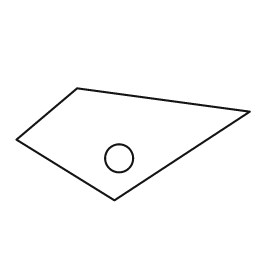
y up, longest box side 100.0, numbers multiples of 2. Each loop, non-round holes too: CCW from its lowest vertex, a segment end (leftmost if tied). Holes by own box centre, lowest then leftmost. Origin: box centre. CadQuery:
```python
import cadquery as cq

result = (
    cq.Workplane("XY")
    .moveTo(-8.0, -24.0)
    .lineTo(50.0, 14.0)
    .lineTo(-24.0, 24.0)
    .lineTo(-50.0, 2.0)
    .close()
    .moveTo(-6.0, -6.0)
    .circle(6.0)
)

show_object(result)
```